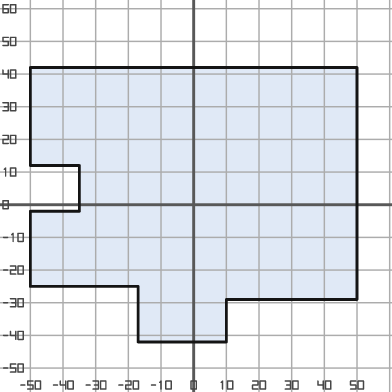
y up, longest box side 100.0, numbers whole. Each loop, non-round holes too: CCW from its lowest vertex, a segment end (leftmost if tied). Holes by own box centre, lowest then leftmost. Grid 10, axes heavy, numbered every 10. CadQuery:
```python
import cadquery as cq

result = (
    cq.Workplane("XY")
    .moveTo(-17.0, -42.0)
    .lineTo(10.0, -42.0)
    .lineTo(10.0, -29.0)
    .lineTo(50.0, -29.0)
    .lineTo(50.0, 42.0)
    .lineTo(-50.0, 42.0)
    .lineTo(-50.0, 12.0)
    .lineTo(-35.0, 12.0)
    .lineTo(-35.0, -2.0)
    .lineTo(-50.0, -2.0)
    .lineTo(-50.0, -25.0)
    .lineTo(-17.0, -25.0)
    .close()
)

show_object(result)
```